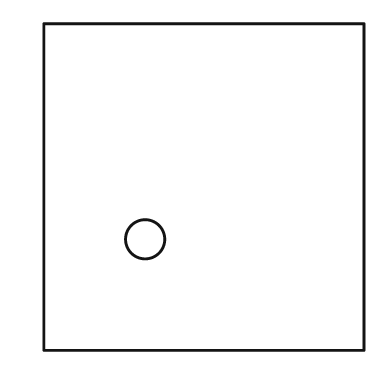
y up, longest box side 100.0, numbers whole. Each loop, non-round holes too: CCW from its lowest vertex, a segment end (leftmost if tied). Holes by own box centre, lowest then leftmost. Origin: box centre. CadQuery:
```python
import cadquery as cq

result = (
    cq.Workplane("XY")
    .moveTo(-49.0, -50.0)
    .lineTo(49.0, -50.0)
    .lineTo(49.0, 50.0)
    .lineTo(-49.0, 50.0)
    .close()
    .moveTo(-18.0, -16.0)
    .circle(6.0)
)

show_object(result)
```